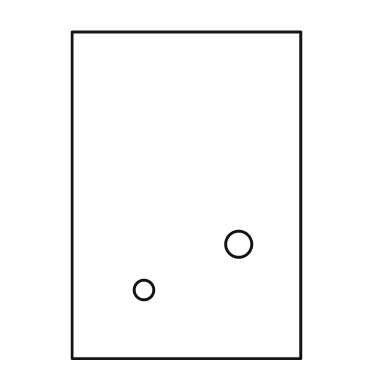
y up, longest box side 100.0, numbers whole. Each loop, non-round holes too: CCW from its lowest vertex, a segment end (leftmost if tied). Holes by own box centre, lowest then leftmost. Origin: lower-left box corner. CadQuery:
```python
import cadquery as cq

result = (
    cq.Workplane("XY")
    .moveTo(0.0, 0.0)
    .lineTo(70.0, 0.0)
    .lineTo(70.0, 100.0)
    .lineTo(0.0, 100.0)
    .close()
    .moveTo(22.0, 21.0)
    .circle(3.0)
    .moveTo(51.0, 35.0)
    .circle(4.0)
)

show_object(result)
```